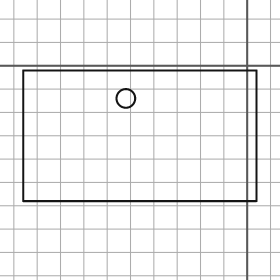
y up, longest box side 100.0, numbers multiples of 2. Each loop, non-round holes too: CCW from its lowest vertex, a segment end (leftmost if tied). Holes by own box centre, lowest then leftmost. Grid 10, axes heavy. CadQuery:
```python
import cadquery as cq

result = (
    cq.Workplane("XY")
    .moveTo(-96.0, -58.0)
    .lineTo(4.0, -58.0)
    .lineTo(4.0, -2.0)
    .lineTo(-96.0, -2.0)
    .close()
    .moveTo(-52.0, -14.0)
    .circle(4.0)
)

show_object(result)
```